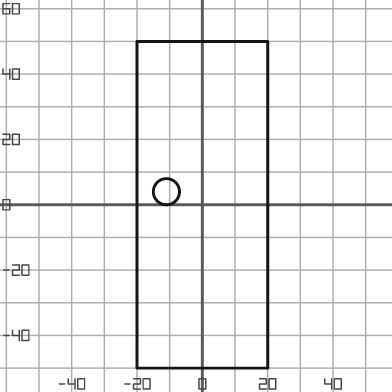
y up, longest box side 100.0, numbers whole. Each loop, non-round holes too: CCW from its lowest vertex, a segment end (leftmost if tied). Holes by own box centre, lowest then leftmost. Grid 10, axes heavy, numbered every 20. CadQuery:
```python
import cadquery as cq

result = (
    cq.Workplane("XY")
    .moveTo(-20.0, -50.0)
    .lineTo(20.0, -50.0)
    .lineTo(20.0, 50.0)
    .lineTo(-20.0, 50.0)
    .close()
    .moveTo(-11.0, 4.0)
    .circle(4.0)
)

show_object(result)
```